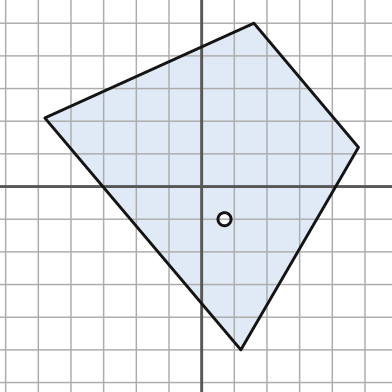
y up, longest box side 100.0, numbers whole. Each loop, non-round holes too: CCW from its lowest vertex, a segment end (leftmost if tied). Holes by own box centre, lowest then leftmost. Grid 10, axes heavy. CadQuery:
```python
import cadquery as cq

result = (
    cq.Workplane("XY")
    .moveTo(12.0, -50.0)
    .lineTo(48.0, 12.0)
    .lineTo(16.0, 50.0)
    .lineTo(-48.0, 21.0)
    .close()
    .moveTo(7.0, -10.0)
    .circle(2.0)
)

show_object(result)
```